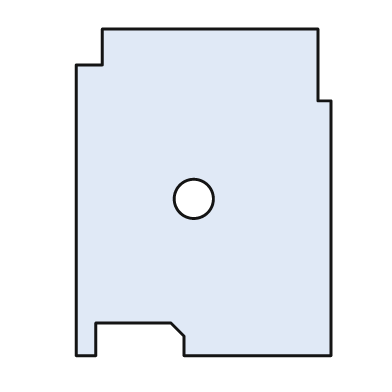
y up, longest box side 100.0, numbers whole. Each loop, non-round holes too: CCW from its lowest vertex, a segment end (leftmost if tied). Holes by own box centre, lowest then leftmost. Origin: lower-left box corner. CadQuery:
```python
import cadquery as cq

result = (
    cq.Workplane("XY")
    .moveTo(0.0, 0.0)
    .lineTo(6.0, 0.0)
    .lineTo(6.0, 10.0)
    .lineTo(29.0, 10.0)
    .lineTo(33.0, 6.0)
    .lineTo(33.0, 0.0)
    .lineTo(78.0, 0.0)
    .lineTo(78.0, 78.0)
    .lineTo(74.0, 78.0)
    .lineTo(74.0, 100.0)
    .lineTo(8.0, 100.0)
    .lineTo(8.0, 89.0)
    .lineTo(0.0, 89.0)
    .close()
    .moveTo(36.0, 48.0)
    .circle(6.0)
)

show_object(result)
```